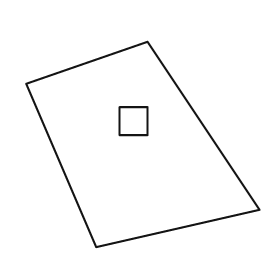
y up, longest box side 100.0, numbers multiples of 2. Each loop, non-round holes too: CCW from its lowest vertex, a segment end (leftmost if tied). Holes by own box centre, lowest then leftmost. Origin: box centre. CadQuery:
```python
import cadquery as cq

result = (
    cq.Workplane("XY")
    .moveTo(-20.0, -44.0)
    .lineTo(50.0, -28.0)
    .lineTo(2.0, 44.0)
    .lineTo(-50.0, 26.0)
    .close()
    .moveTo(-10.0, 4.0)
    .lineTo(2.0, 4.0)
    .lineTo(2.0, 16.0)
    .lineTo(-10.0, 16.0)
    .close()
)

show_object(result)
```